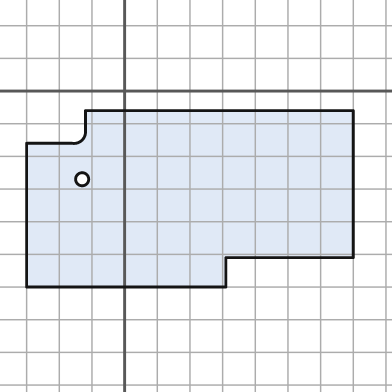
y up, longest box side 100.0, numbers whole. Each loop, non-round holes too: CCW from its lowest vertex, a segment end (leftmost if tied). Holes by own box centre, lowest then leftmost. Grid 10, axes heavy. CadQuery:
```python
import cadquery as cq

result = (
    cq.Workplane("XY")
    .moveTo(-30.0, -60.0)
    .lineTo(31.0, -60.0)
    .lineTo(31.0, -51.0)
    .lineTo(70.0, -51.0)
    .lineTo(70.0, -6.0)
    .lineTo(-12.0, -6.0)
    .lineTo(-12.0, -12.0)
    .threePointArc((-13.0, -15.0), (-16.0, -16.0))
    .lineTo(-30.0, -16.0)
    .close()
    .moveTo(-13.0, -27.0)
    .circle(2.0)
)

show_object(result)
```